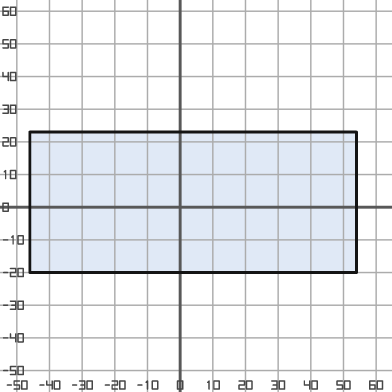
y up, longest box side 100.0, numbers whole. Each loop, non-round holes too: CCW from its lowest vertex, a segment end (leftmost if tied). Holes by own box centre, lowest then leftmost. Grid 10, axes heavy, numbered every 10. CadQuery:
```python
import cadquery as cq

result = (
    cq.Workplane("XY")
    .moveTo(-46.0, -20.0)
    .lineTo(54.0, -20.0)
    .lineTo(54.0, 23.0)
    .lineTo(-46.0, 23.0)
    .close()
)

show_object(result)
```